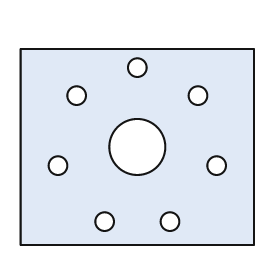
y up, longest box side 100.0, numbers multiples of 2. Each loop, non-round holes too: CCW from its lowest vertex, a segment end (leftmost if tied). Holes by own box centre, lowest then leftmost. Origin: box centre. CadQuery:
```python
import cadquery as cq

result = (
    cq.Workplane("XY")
    .moveTo(-50.0, -42.0)
    .lineTo(50.0, -42.0)
    .lineTo(50.0, 42.0)
    .lineTo(-50.0, 42.0)
    .close()
    .moveTo(-14.0, -32.0)
    .circle(4.0)
    .moveTo(14.0, -32.0)
    .circle(4.0)
    .moveTo(-34.0, -8.0)
    .circle(4.0)
    .moveTo(34.0, -8.0)
    .circle(4.0)
    .moveTo(0.0, 0.0)
    .circle(12.0)
    .moveTo(-26.0, 22.0)
    .circle(4.0)
    .moveTo(26.0, 22.0)
    .circle(4.0)
    .moveTo(0.0, 34.0)
    .circle(4.0)
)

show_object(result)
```